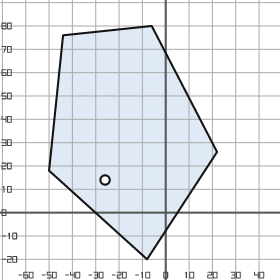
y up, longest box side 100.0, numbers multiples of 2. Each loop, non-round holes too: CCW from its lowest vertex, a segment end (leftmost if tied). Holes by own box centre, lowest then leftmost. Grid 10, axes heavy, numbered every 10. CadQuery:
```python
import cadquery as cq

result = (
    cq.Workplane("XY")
    .moveTo(-8.0, -20.0)
    .lineTo(22.0, 26.0)
    .lineTo(-6.0, 80.0)
    .lineTo(-44.0, 76.0)
    .lineTo(-50.0, 18.0)
    .close()
    .moveTo(-26.0, 14.0)
    .circle(2.0)
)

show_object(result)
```